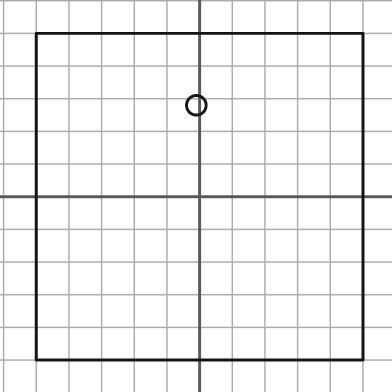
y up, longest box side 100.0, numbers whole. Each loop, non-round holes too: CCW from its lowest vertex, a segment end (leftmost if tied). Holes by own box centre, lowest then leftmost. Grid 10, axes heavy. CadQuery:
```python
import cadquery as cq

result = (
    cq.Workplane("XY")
    .moveTo(-50.0, -50.0)
    .lineTo(50.0, -50.0)
    .lineTo(50.0, 50.0)
    .lineTo(-50.0, 50.0)
    .close()
    .moveTo(-1.0, 28.0)
    .circle(3.0)
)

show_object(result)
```